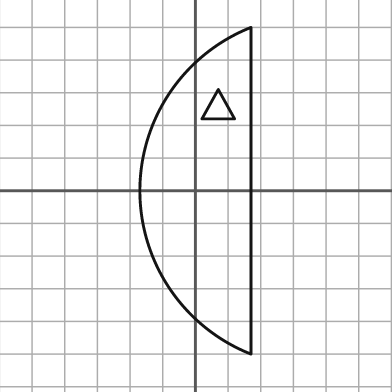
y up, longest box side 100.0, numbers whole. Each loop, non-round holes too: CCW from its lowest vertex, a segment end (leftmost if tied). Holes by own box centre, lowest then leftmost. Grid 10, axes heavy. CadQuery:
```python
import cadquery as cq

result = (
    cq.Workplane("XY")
    .moveTo(17.0, -50.0)
    .lineTo(17.0, 50.0)
    .threePointArc((-17.0, 0.0), (17.0, -50.0))
    .close()
    .moveTo(2.0, 22.0)
    .lineTo(12.0, 22.0)
    .lineTo(7.0, 31.0)
    .close()
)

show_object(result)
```